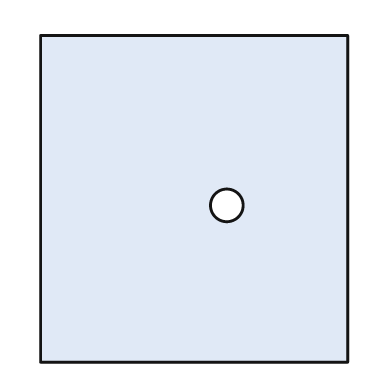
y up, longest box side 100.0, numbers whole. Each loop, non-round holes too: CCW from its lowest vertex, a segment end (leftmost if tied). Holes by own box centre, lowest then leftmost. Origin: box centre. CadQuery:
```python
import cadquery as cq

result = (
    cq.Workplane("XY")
    .moveTo(-47.0, -50.0)
    .lineTo(47.0, -50.0)
    .lineTo(47.0, 50.0)
    .lineTo(-47.0, 50.0)
    .close()
    .moveTo(10.0, -2.0)
    .circle(5.0)
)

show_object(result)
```